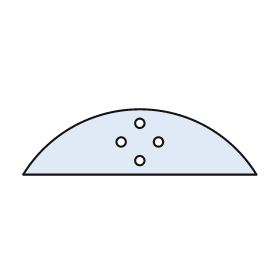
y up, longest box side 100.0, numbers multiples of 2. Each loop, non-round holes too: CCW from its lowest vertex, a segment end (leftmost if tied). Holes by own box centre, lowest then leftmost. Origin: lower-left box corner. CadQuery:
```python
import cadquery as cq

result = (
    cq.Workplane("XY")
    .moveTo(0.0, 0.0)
    .lineTo(100.0, 0.0)
    .threePointArc((50.0, 28.0), (0.0, 0.0))
    .close()
    .moveTo(50.0, 6.0)
    .circle(2.0)
    .moveTo(42.0, 14.0)
    .circle(2.0)
    .moveTo(58.0, 14.0)
    .circle(2.0)
    .moveTo(50.0, 22.0)
    .circle(2.0)
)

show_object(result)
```